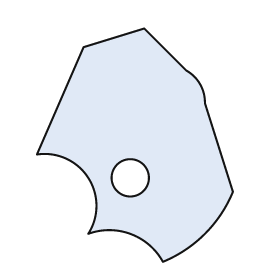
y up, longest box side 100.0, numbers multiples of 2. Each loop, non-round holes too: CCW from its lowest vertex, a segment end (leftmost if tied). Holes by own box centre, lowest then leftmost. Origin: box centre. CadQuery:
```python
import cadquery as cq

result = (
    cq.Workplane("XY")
    .moveTo(12.0, -50.0)
    .threePointArc((30.0, -38.0), (42.0, -20.0))
    .lineTo(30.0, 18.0)
    .threePointArc((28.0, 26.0), (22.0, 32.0))
    .lineTo(4.0, 50.0)
    .lineTo(-22.0, 42.0)
    .lineTo(-42.0, -4.0)
    .threePointArc((-20.0, -14.0), (-20.0, -38.0))
    .threePointArc((-2.0, -38.0), (12.0, -50.0))
    .close()
    .moveTo(-2.0, -14.0)
    .circle(8.0)
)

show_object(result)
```